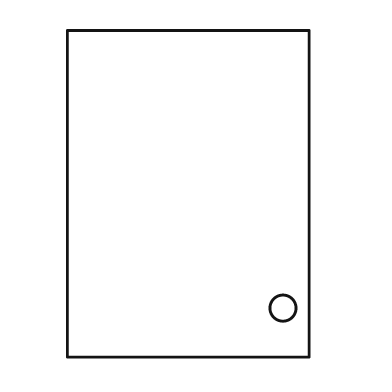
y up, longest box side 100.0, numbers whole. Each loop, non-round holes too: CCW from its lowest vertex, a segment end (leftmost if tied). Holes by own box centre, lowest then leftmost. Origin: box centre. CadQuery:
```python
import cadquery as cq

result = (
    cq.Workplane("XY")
    .moveTo(-37.0, -50.0)
    .lineTo(37.0, -50.0)
    .lineTo(37.0, 50.0)
    .lineTo(-37.0, 50.0)
    .close()
    .moveTo(29.0, -35.0)
    .circle(4.0)
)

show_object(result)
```